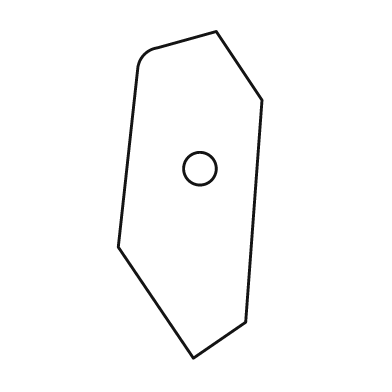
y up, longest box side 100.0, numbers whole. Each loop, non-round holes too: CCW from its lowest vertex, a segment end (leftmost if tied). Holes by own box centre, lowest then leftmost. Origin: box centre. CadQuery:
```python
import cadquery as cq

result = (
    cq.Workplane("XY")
    .moveTo(1.0, -50.0)
    .lineTo(17.0, -39.0)
    .lineTo(22.0, 29.0)
    .lineTo(8.0, 50.0)
    .lineTo(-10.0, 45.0)
    .threePointArc((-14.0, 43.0), (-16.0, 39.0))
    .lineTo(-22.0, -16.0)
    .close()
    .moveTo(3.0, 8.0)
    .circle(5.0)
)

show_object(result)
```